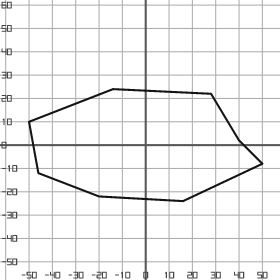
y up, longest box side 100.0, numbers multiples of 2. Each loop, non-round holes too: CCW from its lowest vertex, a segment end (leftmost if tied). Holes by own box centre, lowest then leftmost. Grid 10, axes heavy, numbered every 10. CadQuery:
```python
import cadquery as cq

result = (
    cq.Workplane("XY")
    .moveTo(16.0, -24.0)
    .lineTo(50.0, -8.0)
    .lineTo(40.0, 2.0)
    .lineTo(28.0, 22.0)
    .lineTo(-14.0, 24.0)
    .lineTo(-50.0, 10.0)
    .lineTo(-46.0, -12.0)
    .lineTo(-20.0, -22.0)
    .close()
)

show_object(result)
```